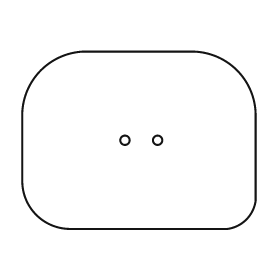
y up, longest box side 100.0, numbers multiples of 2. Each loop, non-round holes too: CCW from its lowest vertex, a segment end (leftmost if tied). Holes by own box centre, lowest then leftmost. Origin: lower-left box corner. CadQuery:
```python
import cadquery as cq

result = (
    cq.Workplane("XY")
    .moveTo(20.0, 0.0)
    .lineTo(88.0, 0.0)
    .threePointArc((96.0, 4.0), (100.0, 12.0))
    .lineTo(100.0, 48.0)
    .threePointArc((92.0, 68.0), (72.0, 76.0))
    .lineTo(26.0, 76.0)
    .threePointArc((8.0, 68.0), (0.0, 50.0))
    .lineTo(0.0, 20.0)
    .threePointArc((6.0, 6.0), (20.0, 0.0))
    .close()
    .moveTo(44.0, 38.0)
    .circle(2.0)
    .moveTo(58.0, 38.0)
    .circle(2.0)
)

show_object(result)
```